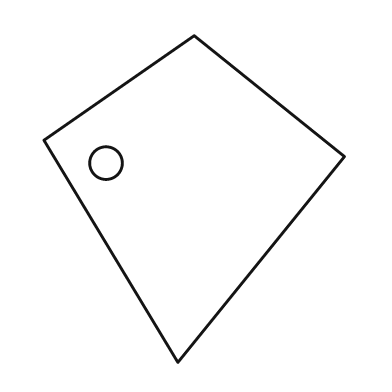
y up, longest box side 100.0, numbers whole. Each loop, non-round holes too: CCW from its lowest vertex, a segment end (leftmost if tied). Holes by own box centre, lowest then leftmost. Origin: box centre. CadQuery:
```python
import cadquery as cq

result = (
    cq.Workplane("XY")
    .moveTo(-5.0, -50.0)
    .lineTo(46.0, 13.0)
    .lineTo(0.0, 50.0)
    .lineTo(-46.0, 18.0)
    .close()
    .moveTo(-27.0, 11.0)
    .circle(5.0)
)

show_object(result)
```